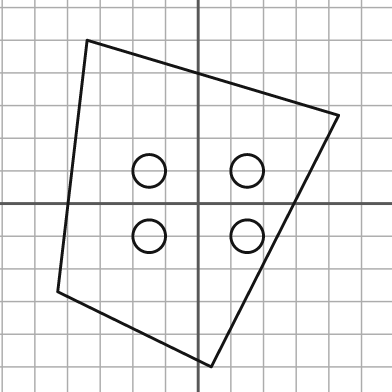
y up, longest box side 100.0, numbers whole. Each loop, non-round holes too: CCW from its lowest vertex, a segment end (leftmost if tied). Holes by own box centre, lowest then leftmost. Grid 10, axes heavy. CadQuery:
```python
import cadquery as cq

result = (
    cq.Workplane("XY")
    .moveTo(4.0, -50.0)
    .lineTo(43.0, 27.0)
    .lineTo(-34.0, 50.0)
    .lineTo(-43.0, -27.0)
    .close()
    .moveTo(-15.0, -10.0)
    .circle(5.0)
    .moveTo(15.0, -10.0)
    .circle(5.0)
    .moveTo(-15.0, 10.0)
    .circle(5.0)
    .moveTo(15.0, 10.0)
    .circle(5.0)
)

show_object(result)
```